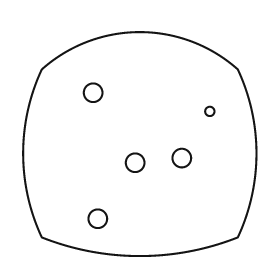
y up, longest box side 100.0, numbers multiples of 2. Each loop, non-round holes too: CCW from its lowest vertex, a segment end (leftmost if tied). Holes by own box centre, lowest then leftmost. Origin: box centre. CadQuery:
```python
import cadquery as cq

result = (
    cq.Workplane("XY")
    .moveTo(-42.0, -40.0)
    .threePointArc((0.0, -48.0), (42.0, -40.0))
    .threePointArc((50.0, -4.0), (42.0, 32.0))
    .threePointArc((0.0, 48.0), (-42.0, 32.0))
    .threePointArc((-50.0, -4.0), (-42.0, -40.0))
    .close()
    .moveTo(-18.0, -32.0)
    .circle(4.0)
    .moveTo(-2.0, -8.0)
    .circle(4.0)
    .moveTo(18.0, -6.0)
    .circle(4.0)
    .moveTo(30.0, 14.0)
    .circle(2.0)
    .moveTo(-20.0, 22.0)
    .circle(4.0)
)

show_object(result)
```